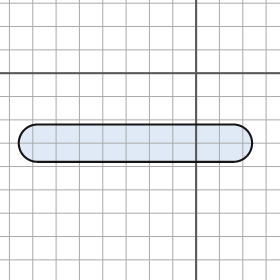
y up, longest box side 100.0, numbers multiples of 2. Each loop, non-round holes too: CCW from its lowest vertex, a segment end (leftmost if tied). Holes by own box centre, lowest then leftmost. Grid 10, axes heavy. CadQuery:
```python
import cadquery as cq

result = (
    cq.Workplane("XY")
    .moveTo(-68.0, -38.0)
    .lineTo(16.0, -38.0)
    .threePointArc((24.0, -30.0), (16.0, -22.0))
    .lineTo(-68.0, -22.0)
    .threePointArc((-76.0, -30.0), (-68.0, -38.0))
    .close()
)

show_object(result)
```